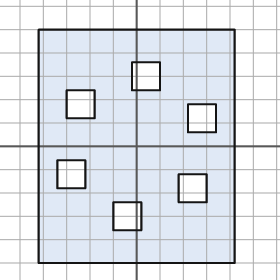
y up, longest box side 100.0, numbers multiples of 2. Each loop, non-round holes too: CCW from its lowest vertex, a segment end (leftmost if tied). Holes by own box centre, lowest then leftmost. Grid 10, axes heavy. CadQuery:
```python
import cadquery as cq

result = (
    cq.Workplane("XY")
    .moveTo(-42.0, -50.0)
    .lineTo(42.0, -50.0)
    .lineTo(42.0, 50.0)
    .lineTo(-42.0, 50.0)
    .close()
    .moveTo(-10.0, -36.0)
    .lineTo(2.0, -36.0)
    .lineTo(2.0, -24.0)
    .lineTo(-10.0, -24.0)
    .close()
    .moveTo(18.0, -24.0)
    .lineTo(30.0, -24.0)
    .lineTo(30.0, -12.0)
    .lineTo(18.0, -12.0)
    .close()
    .moveTo(-34.0, -18.0)
    .lineTo(-22.0, -18.0)
    .lineTo(-22.0, -6.0)
    .lineTo(-34.0, -6.0)
    .close()
    .moveTo(22.0, 6.0)
    .lineTo(34.0, 6.0)
    .lineTo(34.0, 18.0)
    .lineTo(22.0, 18.0)
    .close()
    .moveTo(-30.0, 12.0)
    .lineTo(-18.0, 12.0)
    .lineTo(-18.0, 24.0)
    .lineTo(-30.0, 24.0)
    .close()
    .moveTo(-2.0, 24.0)
    .lineTo(10.0, 24.0)
    .lineTo(10.0, 36.0)
    .lineTo(-2.0, 36.0)
    .close()
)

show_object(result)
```